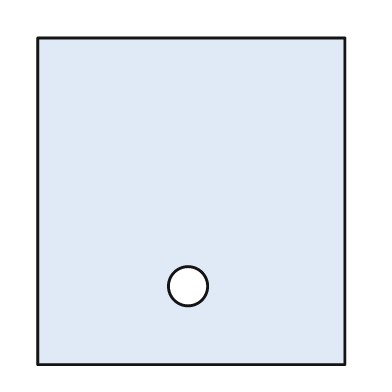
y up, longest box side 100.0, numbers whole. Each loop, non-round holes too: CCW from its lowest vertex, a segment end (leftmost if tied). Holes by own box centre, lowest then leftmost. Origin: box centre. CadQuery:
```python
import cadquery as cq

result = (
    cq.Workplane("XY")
    .moveTo(-47.0, -50.0)
    .lineTo(47.0, -50.0)
    .lineTo(47.0, 50.0)
    .lineTo(-47.0, 50.0)
    .close()
    .moveTo(-1.0, -26.0)
    .circle(6.0)
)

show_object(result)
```